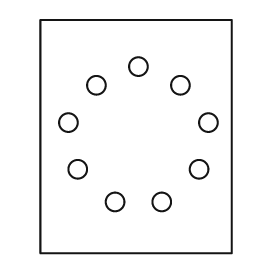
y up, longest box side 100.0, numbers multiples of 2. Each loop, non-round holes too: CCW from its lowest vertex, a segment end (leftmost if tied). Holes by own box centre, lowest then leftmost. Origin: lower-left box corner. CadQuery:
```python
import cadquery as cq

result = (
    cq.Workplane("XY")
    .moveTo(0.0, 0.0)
    .lineTo(82.0, 0.0)
    .lineTo(82.0, 100.0)
    .lineTo(0.0, 100.0)
    .close()
    .moveTo(32.0, 22.0)
    .circle(4.0)
    .moveTo(52.0, 22.0)
    .circle(4.0)
    .moveTo(16.0, 36.0)
    .circle(4.0)
    .moveTo(68.0, 36.0)
    .circle(4.0)
    .moveTo(12.0, 56.0)
    .circle(4.0)
    .moveTo(72.0, 56.0)
    .circle(4.0)
    .moveTo(24.0, 72.0)
    .circle(4.0)
    .moveTo(60.0, 72.0)
    .circle(4.0)
    .moveTo(42.0, 80.0)
    .circle(4.0)
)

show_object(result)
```